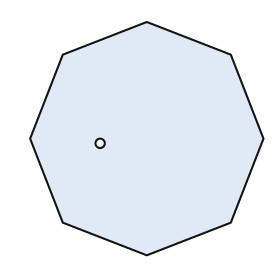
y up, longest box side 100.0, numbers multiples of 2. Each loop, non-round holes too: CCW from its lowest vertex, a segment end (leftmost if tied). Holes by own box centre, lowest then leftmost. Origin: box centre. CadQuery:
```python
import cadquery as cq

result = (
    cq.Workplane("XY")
    .moveTo(0.0, -50.0)
    .lineTo(36.0, -36.0)
    .lineTo(50.0, 0.0)
    .lineTo(36.0, 36.0)
    .lineTo(0.0, 50.0)
    .lineTo(-36.0, 36.0)
    .lineTo(-50.0, 0.0)
    .lineTo(-36.0, -36.0)
    .close()
    .moveTo(-20.0, -2.0)
    .circle(2.0)
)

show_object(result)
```